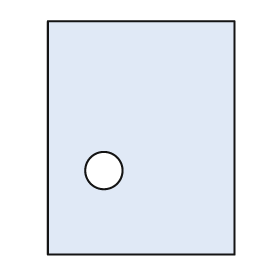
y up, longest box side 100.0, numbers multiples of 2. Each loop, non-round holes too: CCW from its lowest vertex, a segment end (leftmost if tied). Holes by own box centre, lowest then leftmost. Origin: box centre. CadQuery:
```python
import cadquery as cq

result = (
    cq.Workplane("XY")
    .moveTo(-40.0, -50.0)
    .lineTo(40.0, -50.0)
    .lineTo(40.0, 50.0)
    .lineTo(-40.0, 50.0)
    .close()
    .moveTo(-16.0, -14.0)
    .circle(8.0)
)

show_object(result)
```